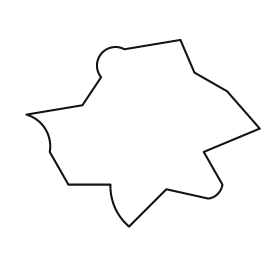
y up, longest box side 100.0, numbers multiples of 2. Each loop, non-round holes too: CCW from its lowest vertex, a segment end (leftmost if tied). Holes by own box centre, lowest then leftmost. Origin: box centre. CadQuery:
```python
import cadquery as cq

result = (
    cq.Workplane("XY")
    .moveTo(-6.0, -40.0)
    .lineTo(10.0, -24.0)
    .lineTo(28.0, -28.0)
    .threePointArc((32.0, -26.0), (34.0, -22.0))
    .lineTo(26.0, -8.0)
    .lineTo(50.0, 2.0)
    .lineTo(36.0, 18.0)
    .lineTo(22.0, 26.0)
    .lineTo(16.0, 40.0)
    .lineTo(-8.0, 36.0)
    .threePointArc((-18.0, 34.0), (-18.0, 24.0))
    .lineTo(-26.0, 12.0)
    .lineTo(-50.0, 8.0)
    .threePointArc((-42.0, 2.0), (-40.0, -8.0))
    .lineTo(-32.0, -22.0)
    .lineTo(-14.0, -22.0)
    .threePointArc((-12.0, -32.0), (-6.0, -40.0))
    .close()
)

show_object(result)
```